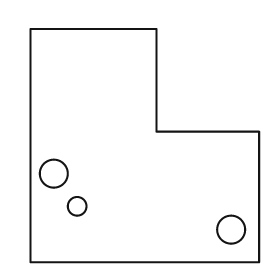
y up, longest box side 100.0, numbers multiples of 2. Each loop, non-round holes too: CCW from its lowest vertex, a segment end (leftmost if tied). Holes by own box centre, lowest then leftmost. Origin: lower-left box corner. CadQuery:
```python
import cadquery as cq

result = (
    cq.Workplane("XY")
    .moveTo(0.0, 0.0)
    .lineTo(98.0, 0.0)
    .lineTo(98.0, 56.0)
    .lineTo(54.0, 56.0)
    .lineTo(54.0, 100.0)
    .lineTo(0.0, 100.0)
    .close()
    .moveTo(86.0, 14.0)
    .circle(6.0)
    .moveTo(20.0, 24.0)
    .circle(4.0)
    .moveTo(10.0, 38.0)
    .circle(6.0)
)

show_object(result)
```